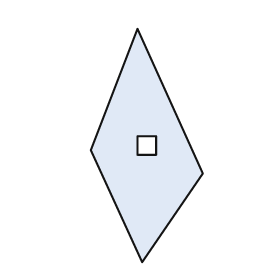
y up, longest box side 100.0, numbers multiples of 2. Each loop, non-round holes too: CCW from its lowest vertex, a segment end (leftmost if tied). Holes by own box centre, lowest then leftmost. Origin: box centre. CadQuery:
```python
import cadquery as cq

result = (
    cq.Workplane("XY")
    .moveTo(-2.0, -50.0)
    .lineTo(24.0, -12.0)
    .lineTo(-4.0, 50.0)
    .lineTo(-24.0, -2.0)
    .close()
    .moveTo(-4.0, -4.0)
    .lineTo(4.0, -4.0)
    .lineTo(4.0, 4.0)
    .lineTo(-4.0, 4.0)
    .close()
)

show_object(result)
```